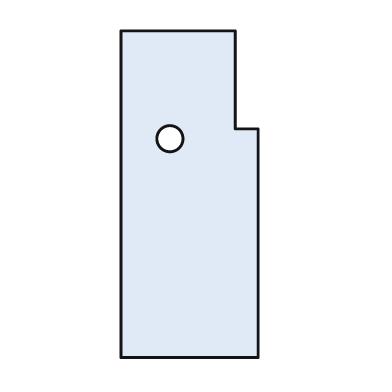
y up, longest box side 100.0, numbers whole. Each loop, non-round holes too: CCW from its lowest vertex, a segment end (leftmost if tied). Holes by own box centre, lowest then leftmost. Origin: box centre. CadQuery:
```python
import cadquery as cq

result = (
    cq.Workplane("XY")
    .moveTo(-21.0, -50.0)
    .lineTo(21.0, -50.0)
    .lineTo(21.0, 20.0)
    .lineTo(14.0, 20.0)
    .lineTo(14.0, 50.0)
    .lineTo(-21.0, 50.0)
    .close()
    .moveTo(-6.0, 17.0)
    .circle(4.0)
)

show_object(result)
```